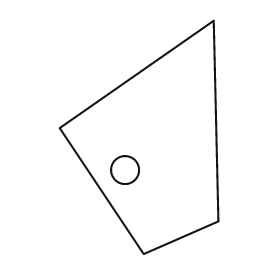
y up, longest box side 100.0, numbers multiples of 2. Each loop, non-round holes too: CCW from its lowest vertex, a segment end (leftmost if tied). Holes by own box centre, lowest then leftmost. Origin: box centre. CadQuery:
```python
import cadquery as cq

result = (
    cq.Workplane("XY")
    .moveTo(2.0, -50.0)
    .lineTo(34.0, -36.0)
    .lineTo(32.0, 50.0)
    .lineTo(-34.0, 4.0)
    .close()
    .moveTo(-6.0, -14.0)
    .circle(6.0)
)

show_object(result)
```